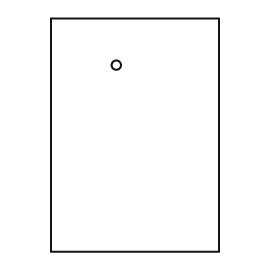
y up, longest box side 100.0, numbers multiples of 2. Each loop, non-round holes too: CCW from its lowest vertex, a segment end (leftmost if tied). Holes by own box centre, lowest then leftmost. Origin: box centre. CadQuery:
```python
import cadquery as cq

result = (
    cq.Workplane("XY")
    .moveTo(-36.0, -50.0)
    .lineTo(36.0, -50.0)
    .lineTo(36.0, 50.0)
    .lineTo(-36.0, 50.0)
    .close()
    .moveTo(-8.0, 30.0)
    .circle(2.0)
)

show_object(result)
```